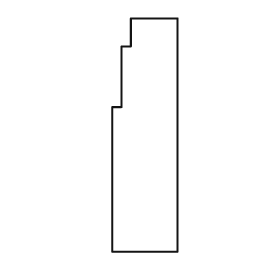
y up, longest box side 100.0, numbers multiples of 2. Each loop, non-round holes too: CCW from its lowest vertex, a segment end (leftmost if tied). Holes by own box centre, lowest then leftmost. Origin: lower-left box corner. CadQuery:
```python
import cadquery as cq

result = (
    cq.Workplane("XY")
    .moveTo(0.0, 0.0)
    .lineTo(28.0, 0.0)
    .lineTo(28.0, 100.0)
    .lineTo(8.0, 100.0)
    .lineTo(8.0, 88.0)
    .lineTo(4.0, 88.0)
    .lineTo(4.0, 62.0)
    .lineTo(0.0, 62.0)
    .close()
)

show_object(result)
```